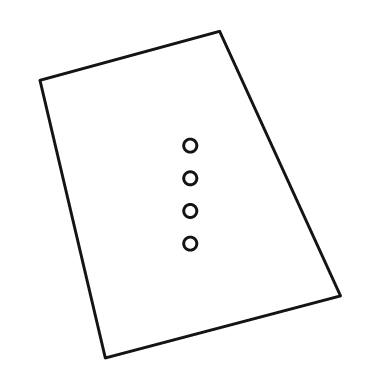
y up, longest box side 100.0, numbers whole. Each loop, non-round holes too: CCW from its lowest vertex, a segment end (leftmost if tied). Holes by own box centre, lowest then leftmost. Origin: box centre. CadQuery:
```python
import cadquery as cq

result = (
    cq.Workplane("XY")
    .moveTo(-26.0, -50.0)
    .lineTo(46.0, -31.0)
    .lineTo(9.0, 50.0)
    .lineTo(-46.0, 35.0)
    .close()
    .moveTo(0.0, -15.0)
    .circle(2.0)
    .moveTo(0.0, -5.0)
    .circle(2.0)
    .moveTo(0.0, 5.0)
    .circle(2.0)
    .moveTo(0.0, 15.0)
    .circle(2.0)
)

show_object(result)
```